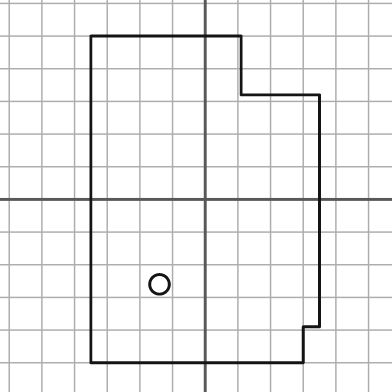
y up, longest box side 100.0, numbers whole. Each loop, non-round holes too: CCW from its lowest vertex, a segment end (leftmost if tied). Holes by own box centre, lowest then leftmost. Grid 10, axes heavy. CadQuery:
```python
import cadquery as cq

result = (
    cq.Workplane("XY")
    .moveTo(-35.0, -50.0)
    .lineTo(30.0, -50.0)
    .lineTo(30.0, -39.0)
    .lineTo(35.0, -39.0)
    .lineTo(35.0, 32.0)
    .lineTo(11.0, 32.0)
    .lineTo(11.0, 50.0)
    .lineTo(-35.0, 50.0)
    .close()
    .moveTo(-14.0, -26.0)
    .circle(3.0)
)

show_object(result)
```